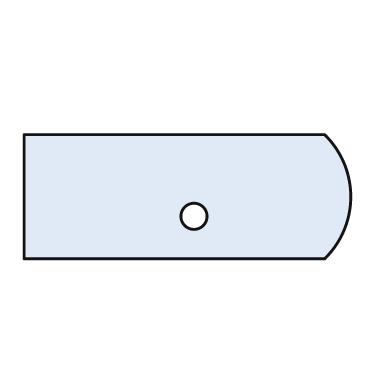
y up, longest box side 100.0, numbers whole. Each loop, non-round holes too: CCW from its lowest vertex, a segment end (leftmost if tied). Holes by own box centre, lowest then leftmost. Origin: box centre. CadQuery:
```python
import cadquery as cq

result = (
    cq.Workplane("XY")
    .moveTo(-50.0, -19.0)
    .lineTo(42.0, -19.0)
    .threePointArc((50.0, 0.0), (42.0, 19.0))
    .lineTo(-50.0, 19.0)
    .close()
    .moveTo(2.0, -6.0)
    .circle(4.0)
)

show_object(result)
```